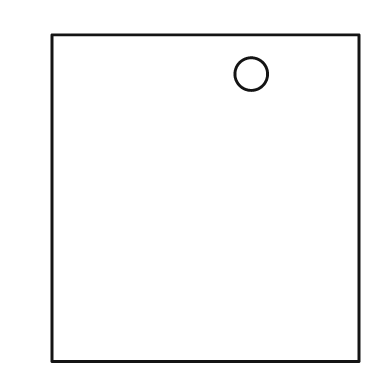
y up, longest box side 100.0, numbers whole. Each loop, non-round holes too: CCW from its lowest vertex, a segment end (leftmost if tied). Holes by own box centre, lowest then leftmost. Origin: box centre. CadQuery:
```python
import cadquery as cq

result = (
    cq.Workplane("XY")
    .moveTo(-47.0, -50.0)
    .lineTo(47.0, -50.0)
    .lineTo(47.0, 50.0)
    .lineTo(-47.0, 50.0)
    .close()
    .moveTo(14.0, 38.0)
    .circle(5.0)
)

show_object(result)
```